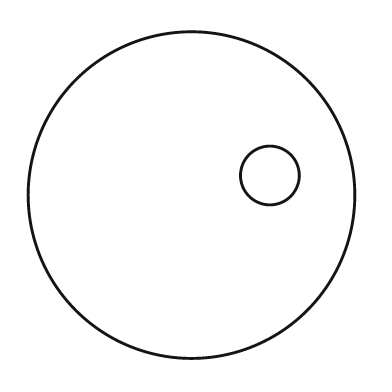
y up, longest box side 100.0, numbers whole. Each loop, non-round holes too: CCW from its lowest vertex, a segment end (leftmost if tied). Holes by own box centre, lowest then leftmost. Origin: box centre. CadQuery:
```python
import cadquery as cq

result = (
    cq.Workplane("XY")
    .moveTo(0.0, 0.0)
    .circle(50.0)
    .moveTo(24.0, 6.0)
    .circle(9.0)
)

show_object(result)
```